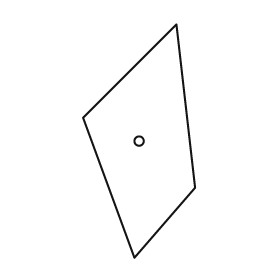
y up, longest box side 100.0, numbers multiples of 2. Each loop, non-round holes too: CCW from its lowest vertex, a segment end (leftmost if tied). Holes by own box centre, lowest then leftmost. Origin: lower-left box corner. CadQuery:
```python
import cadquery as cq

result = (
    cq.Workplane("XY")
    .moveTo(22.0, 0.0)
    .lineTo(48.0, 30.0)
    .lineTo(40.0, 100.0)
    .lineTo(0.0, 60.0)
    .close()
    .moveTo(24.0, 50.0)
    .circle(2.0)
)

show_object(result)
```